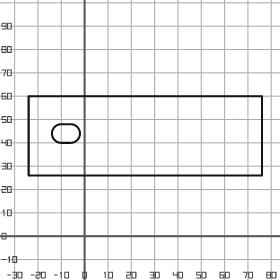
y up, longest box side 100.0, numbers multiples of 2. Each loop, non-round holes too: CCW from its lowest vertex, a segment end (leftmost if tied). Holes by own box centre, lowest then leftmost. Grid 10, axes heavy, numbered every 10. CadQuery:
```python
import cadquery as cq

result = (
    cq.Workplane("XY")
    .moveTo(-24.0, 26.0)
    .lineTo(76.0, 26.0)
    .lineTo(76.0, 60.0)
    .lineTo(-24.0, 60.0)
    .close()
    .moveTo(-10.0, 40.0)
    .lineTo(-6.0, 40.0)
    .threePointArc((-2.0, 44.0), (-6.0, 48.0))
    .lineTo(-10.0, 48.0)
    .threePointArc((-14.0, 44.0), (-10.0, 40.0))
    .close()
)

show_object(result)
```